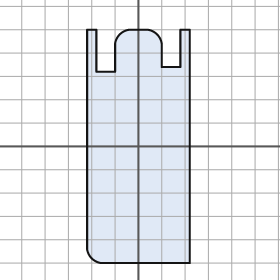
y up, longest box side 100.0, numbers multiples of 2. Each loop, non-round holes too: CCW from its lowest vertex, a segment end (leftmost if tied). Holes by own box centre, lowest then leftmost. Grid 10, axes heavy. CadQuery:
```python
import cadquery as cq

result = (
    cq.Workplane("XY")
    .moveTo(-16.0, -50.0)
    .lineTo(22.0, -50.0)
    .lineTo(22.0, 50.0)
    .lineTo(18.0, 50.0)
    .lineTo(18.0, 34.0)
    .lineTo(10.0, 34.0)
    .lineTo(10.0, 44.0)
    .threePointArc((8.0, 48.0), (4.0, 50.0))
    .lineTo(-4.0, 50.0)
    .threePointArc((-8.0, 48.0), (-10.0, 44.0))
    .lineTo(-10.0, 32.0)
    .lineTo(-18.0, 32.0)
    .lineTo(-18.0, 50.0)
    .lineTo(-22.0, 50.0)
    .lineTo(-22.0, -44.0)
    .threePointArc((-20.0, -48.0), (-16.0, -50.0))
    .close()
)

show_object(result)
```